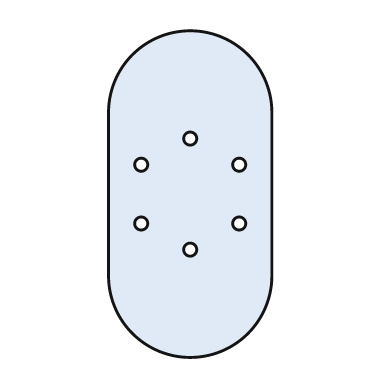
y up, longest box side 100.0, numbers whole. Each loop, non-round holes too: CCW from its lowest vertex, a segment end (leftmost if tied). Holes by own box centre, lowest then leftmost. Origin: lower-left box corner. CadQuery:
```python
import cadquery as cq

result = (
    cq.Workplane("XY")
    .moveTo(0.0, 25.0)
    .threePointArc((25.0, 0.0), (50.0, 25.0))
    .lineTo(50.0, 75.0)
    .threePointArc((25.0, 100.0), (0.0, 75.0))
    .close()
    .moveTo(25.0, 33.0)
    .circle(2.0)
    .moveTo(10.0, 41.0)
    .circle(2.0)
    .moveTo(40.0, 41.0)
    .circle(2.0)
    .moveTo(10.0, 59.0)
    .circle(2.0)
    .moveTo(40.0, 59.0)
    .circle(2.0)
    .moveTo(25.0, 67.0)
    .circle(2.0)
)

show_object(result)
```